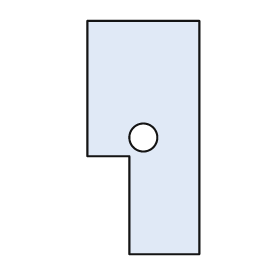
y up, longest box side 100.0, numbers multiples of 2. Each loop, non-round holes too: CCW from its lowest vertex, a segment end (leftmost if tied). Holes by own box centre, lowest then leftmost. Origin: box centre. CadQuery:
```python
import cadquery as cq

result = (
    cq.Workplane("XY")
    .moveTo(-6.0, -50.0)
    .lineTo(24.0, -50.0)
    .lineTo(24.0, 50.0)
    .lineTo(-24.0, 50.0)
    .lineTo(-24.0, -8.0)
    .lineTo(-6.0, -8.0)
    .close()
    .moveTo(0.0, 0.0)
    .circle(6.0)
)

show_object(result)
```